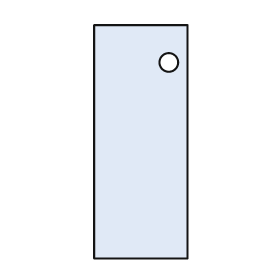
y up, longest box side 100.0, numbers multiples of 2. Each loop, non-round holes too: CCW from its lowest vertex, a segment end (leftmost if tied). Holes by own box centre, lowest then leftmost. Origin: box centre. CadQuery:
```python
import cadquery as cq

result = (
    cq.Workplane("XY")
    .moveTo(-20.0, -50.0)
    .lineTo(20.0, -50.0)
    .lineTo(20.0, 50.0)
    .lineTo(-20.0, 50.0)
    .close()
    .moveTo(12.0, 34.0)
    .circle(4.0)
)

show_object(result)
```